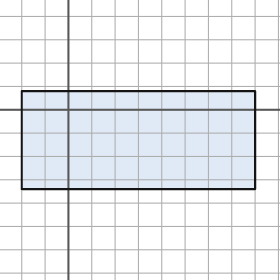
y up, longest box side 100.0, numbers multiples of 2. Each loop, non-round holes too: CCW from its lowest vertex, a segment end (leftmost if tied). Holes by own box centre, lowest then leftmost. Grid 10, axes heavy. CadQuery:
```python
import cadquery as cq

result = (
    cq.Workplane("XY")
    .moveTo(-20.0, -34.0)
    .lineTo(80.0, -34.0)
    .lineTo(80.0, 8.0)
    .lineTo(-20.0, 8.0)
    .close()
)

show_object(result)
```